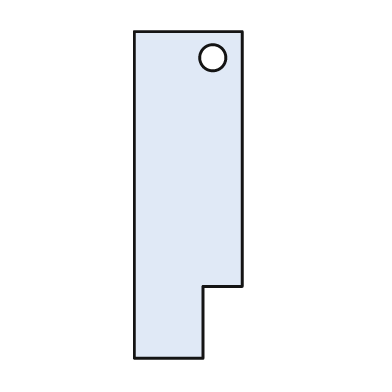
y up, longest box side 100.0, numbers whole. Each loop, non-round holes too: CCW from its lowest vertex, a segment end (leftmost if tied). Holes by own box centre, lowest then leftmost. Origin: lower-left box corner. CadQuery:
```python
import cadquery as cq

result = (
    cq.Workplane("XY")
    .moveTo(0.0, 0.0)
    .lineTo(21.0, 0.0)
    .lineTo(21.0, 22.0)
    .lineTo(33.0, 22.0)
    .lineTo(33.0, 100.0)
    .lineTo(0.0, 100.0)
    .close()
    .moveTo(24.0, 92.0)
    .circle(4.0)
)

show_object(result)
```